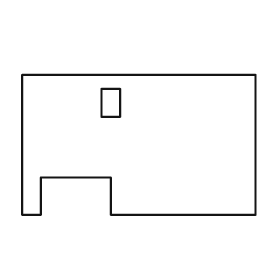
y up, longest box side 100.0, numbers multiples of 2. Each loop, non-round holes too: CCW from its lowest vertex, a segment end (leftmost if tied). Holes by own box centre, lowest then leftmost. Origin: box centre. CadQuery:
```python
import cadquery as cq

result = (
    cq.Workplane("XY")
    .moveTo(-50.0, -30.0)
    .lineTo(-42.0, -30.0)
    .lineTo(-42.0, -14.0)
    .lineTo(-12.0, -14.0)
    .lineTo(-12.0, -30.0)
    .lineTo(50.0, -30.0)
    .lineTo(50.0, 30.0)
    .lineTo(-50.0, 30.0)
    .close()
    .moveTo(-16.0, 12.0)
    .lineTo(-8.0, 12.0)
    .lineTo(-8.0, 24.0)
    .lineTo(-16.0, 24.0)
    .close()
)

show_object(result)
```